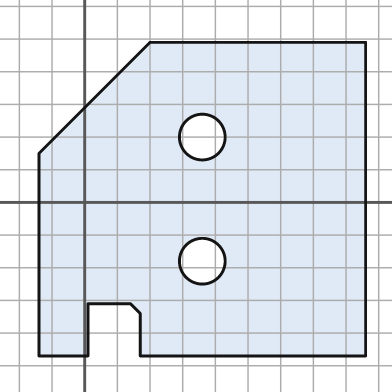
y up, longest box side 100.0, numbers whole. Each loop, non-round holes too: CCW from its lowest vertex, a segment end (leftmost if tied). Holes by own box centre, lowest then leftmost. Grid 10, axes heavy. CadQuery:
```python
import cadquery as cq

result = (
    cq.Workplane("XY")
    .moveTo(-14.0, -47.0)
    .lineTo(1.0, -47.0)
    .lineTo(1.0, -31.0)
    .lineTo(14.0, -31.0)
    .lineTo(17.0, -34.0)
    .lineTo(17.0, -47.0)
    .lineTo(86.0, -47.0)
    .lineTo(86.0, 49.0)
    .lineTo(20.0, 49.0)
    .lineTo(-14.0, 15.0)
    .close()
    .moveTo(36.0, -18.0)
    .circle(7.0)
    .moveTo(36.0, 20.0)
    .circle(7.0)
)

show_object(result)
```